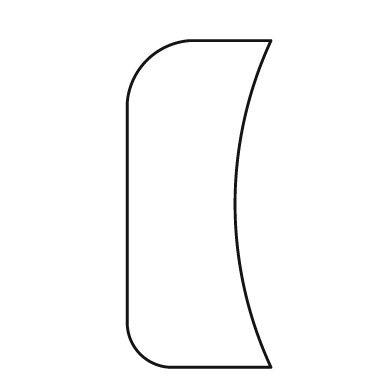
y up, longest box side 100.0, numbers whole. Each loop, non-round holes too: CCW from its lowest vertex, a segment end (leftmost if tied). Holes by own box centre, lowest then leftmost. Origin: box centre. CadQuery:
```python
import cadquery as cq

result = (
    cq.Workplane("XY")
    .moveTo(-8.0, -50.0)
    .lineTo(22.0, -50.0)
    .threePointArc((11.0, 0.0), (22.0, 50.0))
    .lineTo(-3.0, 50.0)
    .threePointArc((-16.0, 44.0), (-22.0, 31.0))
    .lineTo(-22.0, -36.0)
    .threePointArc((-18.0, -46.0), (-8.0, -50.0))
    .close()
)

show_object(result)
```